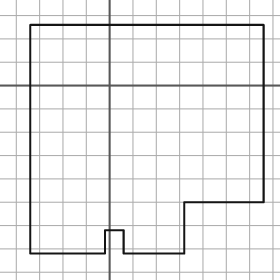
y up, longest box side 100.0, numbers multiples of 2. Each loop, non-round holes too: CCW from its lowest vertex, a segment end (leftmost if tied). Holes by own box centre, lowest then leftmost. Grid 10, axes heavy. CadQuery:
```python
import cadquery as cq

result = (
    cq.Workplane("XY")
    .moveTo(-34.0, -72.0)
    .lineTo(-2.0, -72.0)
    .lineTo(-2.0, -62.0)
    .lineTo(6.0, -62.0)
    .lineTo(6.0, -72.0)
    .lineTo(32.0, -72.0)
    .lineTo(32.0, -50.0)
    .lineTo(66.0, -50.0)
    .lineTo(66.0, 26.0)
    .lineTo(-34.0, 26.0)
    .close()
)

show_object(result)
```